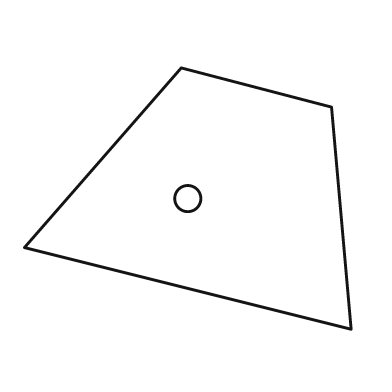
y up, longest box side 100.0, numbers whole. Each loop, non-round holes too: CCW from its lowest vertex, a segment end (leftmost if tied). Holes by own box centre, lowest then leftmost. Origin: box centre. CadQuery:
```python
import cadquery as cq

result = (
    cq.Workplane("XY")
    .moveTo(50.0, -40.0)
    .lineTo(44.0, 28.0)
    .lineTo(-2.0, 40.0)
    .lineTo(-50.0, -15.0)
    .close()
    .moveTo(0.0, 0.0)
    .circle(4.0)
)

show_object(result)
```